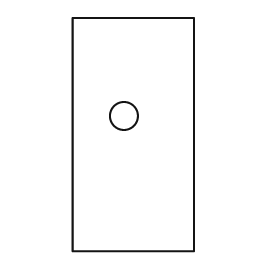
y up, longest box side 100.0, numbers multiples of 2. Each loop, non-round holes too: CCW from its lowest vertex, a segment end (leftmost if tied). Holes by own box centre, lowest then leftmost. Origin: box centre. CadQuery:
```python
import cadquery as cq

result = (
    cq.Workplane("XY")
    .moveTo(-26.0, -50.0)
    .lineTo(26.0, -50.0)
    .lineTo(26.0, 50.0)
    .lineTo(-26.0, 50.0)
    .close()
    .moveTo(-4.0, 8.0)
    .circle(6.0)
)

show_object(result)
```